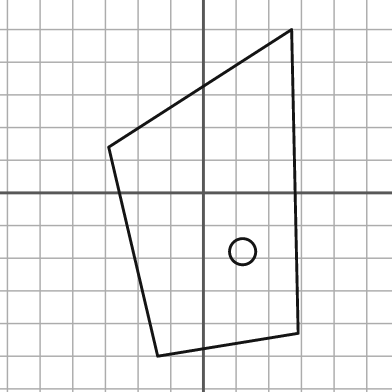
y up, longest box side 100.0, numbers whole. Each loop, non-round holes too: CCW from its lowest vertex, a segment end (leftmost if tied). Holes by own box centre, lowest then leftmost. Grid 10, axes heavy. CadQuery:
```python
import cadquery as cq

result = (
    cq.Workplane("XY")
    .moveTo(-14.0, -50.0)
    .lineTo(29.0, -43.0)
    .lineTo(27.0, 50.0)
    .lineTo(-29.0, 14.0)
    .close()
    .moveTo(12.0, -18.0)
    .circle(4.0)
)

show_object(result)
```